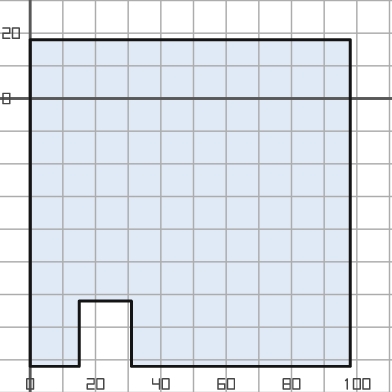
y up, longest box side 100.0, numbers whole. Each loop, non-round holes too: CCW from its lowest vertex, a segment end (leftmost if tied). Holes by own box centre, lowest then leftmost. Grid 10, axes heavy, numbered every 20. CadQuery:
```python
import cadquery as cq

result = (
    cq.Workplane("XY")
    .moveTo(0.0, -82.0)
    .lineTo(15.0, -82.0)
    .lineTo(15.0, -62.0)
    .lineTo(31.0, -62.0)
    .lineTo(31.0, -82.0)
    .lineTo(98.0, -82.0)
    .lineTo(98.0, 18.0)
    .lineTo(0.0, 18.0)
    .close()
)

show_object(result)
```